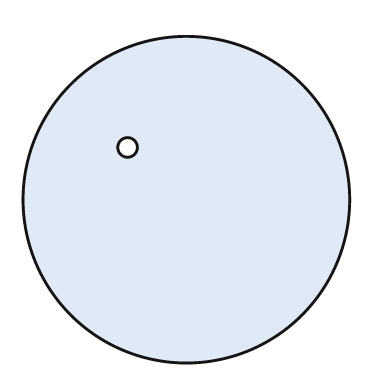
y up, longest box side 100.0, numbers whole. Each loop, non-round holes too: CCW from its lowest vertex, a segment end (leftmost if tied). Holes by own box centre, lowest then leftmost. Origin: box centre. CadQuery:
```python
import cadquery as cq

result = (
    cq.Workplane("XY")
    .moveTo(0.0, 0.0)
    .circle(50.0)
    .moveTo(-18.0, 16.0)
    .circle(3.0)
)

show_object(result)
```